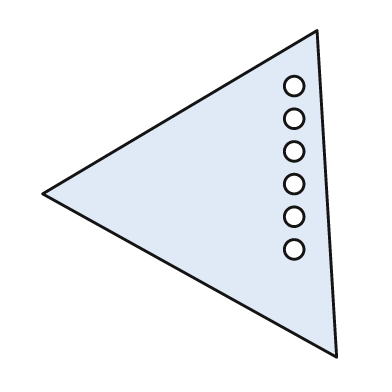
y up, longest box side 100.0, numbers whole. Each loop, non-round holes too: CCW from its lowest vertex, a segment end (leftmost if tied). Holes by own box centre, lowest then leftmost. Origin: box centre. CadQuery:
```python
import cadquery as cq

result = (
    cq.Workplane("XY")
    .moveTo(45.0, -50.0)
    .lineTo(39.0, 50.0)
    .lineTo(-45.0, 0.0)
    .close()
    .moveTo(32.0, -17.0)
    .circle(3.0)
    .moveTo(32.0, -7.0)
    .circle(3.0)
    .moveTo(32.0, 3.0)
    .circle(3.0)
    .moveTo(32.0, 13.0)
    .circle(3.0)
    .moveTo(32.0, 23.0)
    .circle(3.0)
    .moveTo(32.0, 33.0)
    .circle(3.0)
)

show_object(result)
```